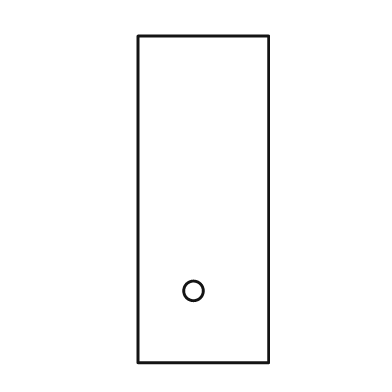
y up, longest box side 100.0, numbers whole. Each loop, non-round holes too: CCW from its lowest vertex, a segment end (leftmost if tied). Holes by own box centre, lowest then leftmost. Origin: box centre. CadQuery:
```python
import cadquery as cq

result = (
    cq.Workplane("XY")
    .moveTo(-20.0, -50.0)
    .lineTo(20.0, -50.0)
    .lineTo(20.0, 50.0)
    .lineTo(-20.0, 50.0)
    .close()
    .moveTo(-3.0, -28.0)
    .circle(3.0)
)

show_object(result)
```